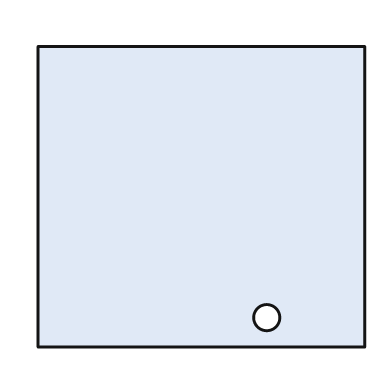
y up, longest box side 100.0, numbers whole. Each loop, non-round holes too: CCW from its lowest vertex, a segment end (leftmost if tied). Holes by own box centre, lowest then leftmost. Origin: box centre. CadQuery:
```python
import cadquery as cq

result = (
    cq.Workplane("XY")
    .moveTo(-50.0, -46.0)
    .lineTo(50.0, -46.0)
    .lineTo(50.0, 46.0)
    .lineTo(-50.0, 46.0)
    .close()
    .moveTo(20.0, -37.0)
    .circle(4.0)
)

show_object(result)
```